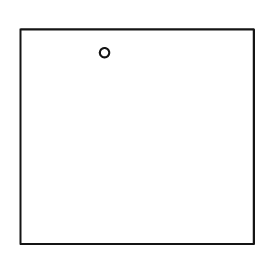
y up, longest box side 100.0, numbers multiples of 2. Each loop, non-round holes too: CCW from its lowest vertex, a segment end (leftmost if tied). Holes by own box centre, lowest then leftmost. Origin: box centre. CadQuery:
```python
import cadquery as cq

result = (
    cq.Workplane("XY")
    .moveTo(-50.0, -46.0)
    .lineTo(50.0, -46.0)
    .lineTo(50.0, 46.0)
    .lineTo(-50.0, 46.0)
    .close()
    .moveTo(-14.0, 36.0)
    .circle(2.0)
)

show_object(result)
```